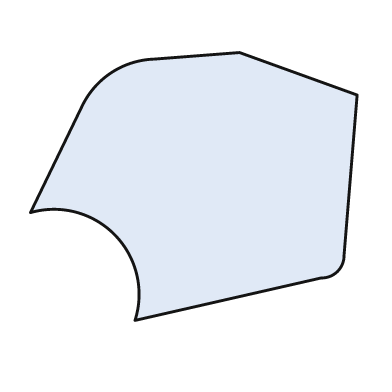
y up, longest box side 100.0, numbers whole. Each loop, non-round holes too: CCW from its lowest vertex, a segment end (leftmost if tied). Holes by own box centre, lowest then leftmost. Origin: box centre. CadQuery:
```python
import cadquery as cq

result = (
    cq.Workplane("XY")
    .moveTo(-18.0, -41.0)
    .lineTo(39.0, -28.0)
    .threePointArc((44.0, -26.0), (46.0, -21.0))
    .lineTo(50.0, 28.0)
    .lineTo(14.0, 41.0)
    .lineTo(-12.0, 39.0)
    .threePointArc((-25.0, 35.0), (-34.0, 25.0))
    .lineTo(-50.0, -8.0)
    .threePointArc((-24.0, -15.0), (-18.0, -41.0))
    .close()
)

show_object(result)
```